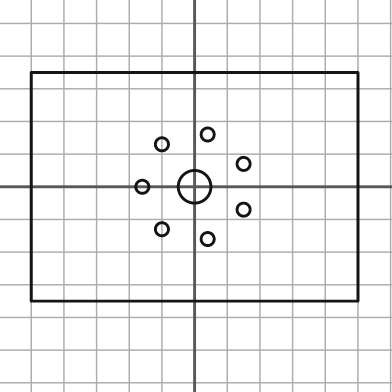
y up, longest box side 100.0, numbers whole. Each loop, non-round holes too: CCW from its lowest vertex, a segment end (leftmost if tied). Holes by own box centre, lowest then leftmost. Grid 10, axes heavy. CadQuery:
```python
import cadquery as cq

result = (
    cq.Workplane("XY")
    .moveTo(-50.0, -35.0)
    .lineTo(50.0, -35.0)
    .lineTo(50.0, 35.0)
    .lineTo(-50.0, 35.0)
    .close()
    .moveTo(4.0, -16.0)
    .circle(2.0)
    .moveTo(-10.0, -13.0)
    .circle(2.0)
    .moveTo(15.0, -7.0)
    .circle(2.0)
    .moveTo(-16.0, 0.0)
    .circle(2.0)
    .moveTo(0.0, 0.0)
    .circle(5.0)
    .moveTo(15.0, 7.0)
    .circle(2.0)
    .moveTo(-10.0, 13.0)
    .circle(2.0)
    .moveTo(4.0, 16.0)
    .circle(2.0)
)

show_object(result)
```